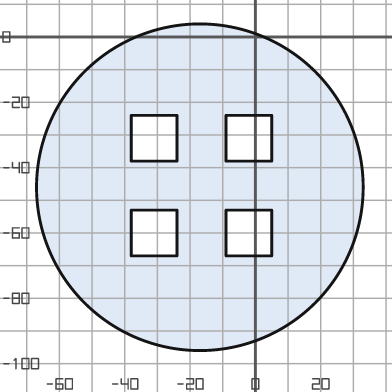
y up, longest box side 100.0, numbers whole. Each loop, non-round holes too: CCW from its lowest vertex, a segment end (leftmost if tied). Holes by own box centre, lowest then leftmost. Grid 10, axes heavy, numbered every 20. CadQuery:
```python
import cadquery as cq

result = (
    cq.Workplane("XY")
    .moveTo(-17.0, -46.0)
    .circle(50.0)
    .moveTo(-38.0, -67.0)
    .lineTo(-24.0, -67.0)
    .lineTo(-24.0, -53.0)
    .lineTo(-38.0, -53.0)
    .close()
    .moveTo(-9.0, -67.0)
    .lineTo(5.0, -67.0)
    .lineTo(5.0, -53.0)
    .lineTo(-9.0, -53.0)
    .close()
    .moveTo(-38.0, -38.0)
    .lineTo(-24.0, -38.0)
    .lineTo(-24.0, -24.0)
    .lineTo(-38.0, -24.0)
    .close()
    .moveTo(-9.0, -38.0)
    .lineTo(5.0, -38.0)
    .lineTo(5.0, -24.0)
    .lineTo(-9.0, -24.0)
    .close()
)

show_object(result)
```